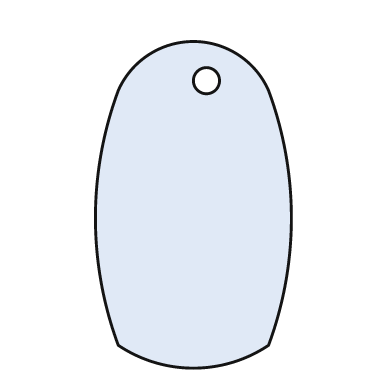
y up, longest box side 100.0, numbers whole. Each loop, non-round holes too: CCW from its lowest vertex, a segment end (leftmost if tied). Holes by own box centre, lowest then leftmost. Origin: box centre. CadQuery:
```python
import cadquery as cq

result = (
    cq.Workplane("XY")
    .moveTo(-23.0, -43.0)
    .threePointArc((0.0, -50.0), (23.0, -43.0))
    .threePointArc((30.0, -4.0), (23.0, 35.0))
    .threePointArc((0.0, 50.0), (-23.0, 35.0))
    .threePointArc((-30.0, -4.0), (-23.0, -43.0))
    .close()
    .moveTo(4.0, 38.0)
    .circle(4.0)
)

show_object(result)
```